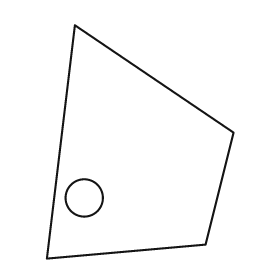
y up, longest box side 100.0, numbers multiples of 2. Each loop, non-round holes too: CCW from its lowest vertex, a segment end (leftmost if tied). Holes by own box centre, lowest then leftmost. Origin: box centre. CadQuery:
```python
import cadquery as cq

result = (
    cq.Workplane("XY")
    .moveTo(-40.0, -50.0)
    .lineTo(28.0, -44.0)
    .lineTo(40.0, 4.0)
    .lineTo(-28.0, 50.0)
    .close()
    .moveTo(-24.0, -24.0)
    .circle(8.0)
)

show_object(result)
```